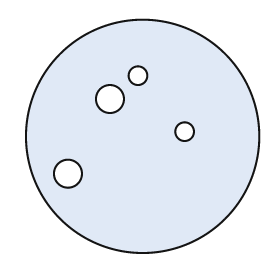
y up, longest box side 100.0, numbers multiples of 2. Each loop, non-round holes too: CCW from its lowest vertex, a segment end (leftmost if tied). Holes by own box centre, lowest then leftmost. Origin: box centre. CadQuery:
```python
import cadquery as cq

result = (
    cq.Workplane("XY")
    .moveTo(0.0, 0.0)
    .circle(50.0)
    .moveTo(-32.0, -16.0)
    .circle(6.0)
    .moveTo(18.0, 2.0)
    .circle(4.0)
    .moveTo(-14.0, 16.0)
    .circle(6.0)
    .moveTo(-2.0, 26.0)
    .circle(4.0)
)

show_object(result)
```